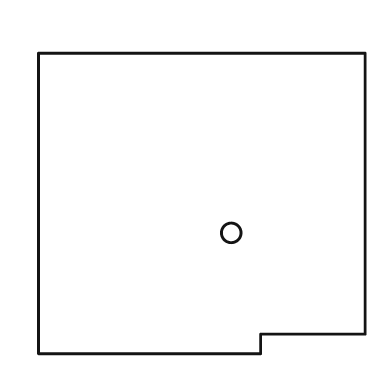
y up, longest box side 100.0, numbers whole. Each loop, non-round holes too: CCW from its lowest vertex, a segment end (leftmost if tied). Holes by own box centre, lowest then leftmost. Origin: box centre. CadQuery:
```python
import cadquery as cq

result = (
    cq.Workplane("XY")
    .moveTo(-50.0, -46.0)
    .lineTo(18.0, -46.0)
    .lineTo(18.0, -40.0)
    .lineTo(50.0, -40.0)
    .lineTo(50.0, 46.0)
    .lineTo(-50.0, 46.0)
    .close()
    .moveTo(9.0, -9.0)
    .circle(3.0)
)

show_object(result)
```